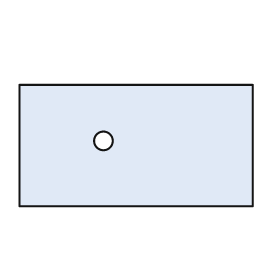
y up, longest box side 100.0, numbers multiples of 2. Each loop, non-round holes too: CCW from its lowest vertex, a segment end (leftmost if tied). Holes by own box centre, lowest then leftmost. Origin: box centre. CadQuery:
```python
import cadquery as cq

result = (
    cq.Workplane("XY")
    .moveTo(-50.0, -26.0)
    .lineTo(50.0, -26.0)
    .lineTo(50.0, 26.0)
    .lineTo(-50.0, 26.0)
    .close()
    .moveTo(-14.0, 2.0)
    .circle(4.0)
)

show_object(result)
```